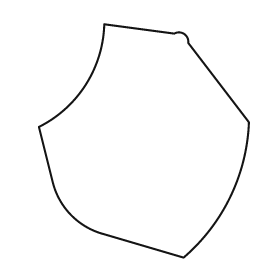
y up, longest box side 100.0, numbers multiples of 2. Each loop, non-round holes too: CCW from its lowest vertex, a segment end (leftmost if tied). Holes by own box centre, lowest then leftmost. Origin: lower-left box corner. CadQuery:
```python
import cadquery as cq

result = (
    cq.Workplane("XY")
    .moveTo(62.0, 0.0)
    .threePointArc((82.0, 26.0), (90.0, 58.0))
    .lineTo(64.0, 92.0)
    .threePointArc((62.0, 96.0), (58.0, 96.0))
    .lineTo(28.0, 100.0)
    .threePointArc((20.0, 74.0), (0.0, 56.0))
    .lineTo(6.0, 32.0)
    .threePointArc((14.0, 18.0), (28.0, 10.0))
    .close()
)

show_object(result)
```